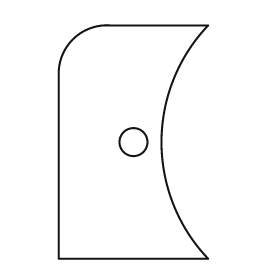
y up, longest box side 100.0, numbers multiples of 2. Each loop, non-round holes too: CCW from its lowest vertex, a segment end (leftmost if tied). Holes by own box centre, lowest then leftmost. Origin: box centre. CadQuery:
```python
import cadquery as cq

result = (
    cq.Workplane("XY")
    .moveTo(-32.0, -50.0)
    .lineTo(32.0, -50.0)
    .threePointArc((12.0, 0.0), (32.0, 50.0))
    .lineTo(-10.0, 50.0)
    .threePointArc((-26.0, 44.0), (-32.0, 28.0))
    .close()
    .moveTo(0.0, 0.0)
    .circle(6.0)
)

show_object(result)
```